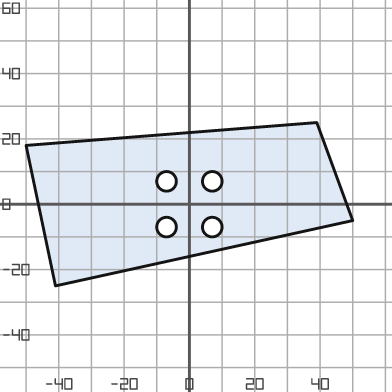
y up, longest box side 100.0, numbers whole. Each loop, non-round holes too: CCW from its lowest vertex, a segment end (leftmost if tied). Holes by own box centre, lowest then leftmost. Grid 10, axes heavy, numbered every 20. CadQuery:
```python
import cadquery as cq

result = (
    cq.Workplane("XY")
    .moveTo(-41.0, -25.0)
    .lineTo(50.0, -5.0)
    .lineTo(39.0, 25.0)
    .lineTo(-50.0, 18.0)
    .close()
    .moveTo(-7.0, -7.0)
    .circle(3.0)
    .moveTo(7.0, -7.0)
    .circle(3.0)
    .moveTo(-7.0, 7.0)
    .circle(3.0)
    .moveTo(7.0, 7.0)
    .circle(3.0)
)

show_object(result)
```